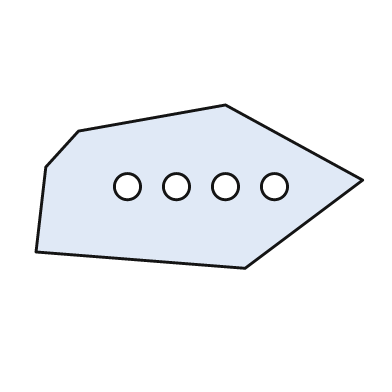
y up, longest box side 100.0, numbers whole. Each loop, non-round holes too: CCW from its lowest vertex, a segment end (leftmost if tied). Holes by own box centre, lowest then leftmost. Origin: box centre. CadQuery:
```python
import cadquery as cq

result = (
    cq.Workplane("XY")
    .moveTo(14.0, -25.0)
    .lineTo(50.0, 2.0)
    .lineTo(8.0, 25.0)
    .lineTo(-37.0, 17.0)
    .lineTo(-47.0, 6.0)
    .lineTo(-50.0, -20.0)
    .close()
    .moveTo(-22.0, 0.0)
    .circle(4.0)
    .moveTo(-7.0, 0.0)
    .circle(4.0)
    .moveTo(8.0, 0.0)
    .circle(4.0)
    .moveTo(23.0, 0.0)
    .circle(4.0)
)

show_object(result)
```